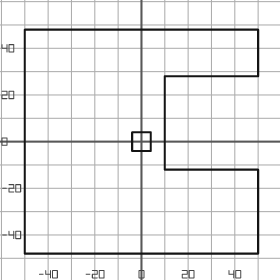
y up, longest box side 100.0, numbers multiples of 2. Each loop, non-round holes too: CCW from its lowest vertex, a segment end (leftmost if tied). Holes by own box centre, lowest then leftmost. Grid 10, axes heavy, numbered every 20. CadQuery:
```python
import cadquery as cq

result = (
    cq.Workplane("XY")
    .moveTo(-50.0, -48.0)
    .lineTo(50.0, -48.0)
    .lineTo(50.0, -12.0)
    .lineTo(10.0, -12.0)
    .lineTo(10.0, 28.0)
    .lineTo(50.0, 28.0)
    .lineTo(50.0, 48.0)
    .lineTo(-50.0, 48.0)
    .close()
    .moveTo(-4.0, -4.0)
    .lineTo(4.0, -4.0)
    .lineTo(4.0, 4.0)
    .lineTo(-4.0, 4.0)
    .close()
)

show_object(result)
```